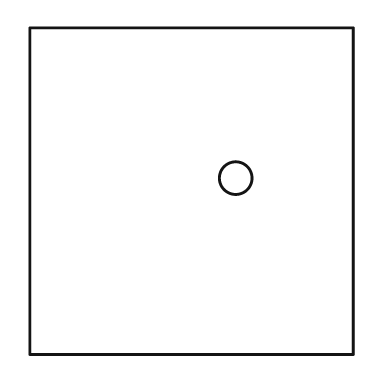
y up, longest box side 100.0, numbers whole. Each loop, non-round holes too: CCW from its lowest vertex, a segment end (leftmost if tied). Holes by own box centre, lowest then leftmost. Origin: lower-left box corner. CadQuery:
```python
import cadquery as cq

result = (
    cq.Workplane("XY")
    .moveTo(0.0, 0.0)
    .lineTo(99.0, 0.0)
    .lineTo(99.0, 100.0)
    .lineTo(0.0, 100.0)
    .close()
    .moveTo(63.0, 54.0)
    .circle(5.0)
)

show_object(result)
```